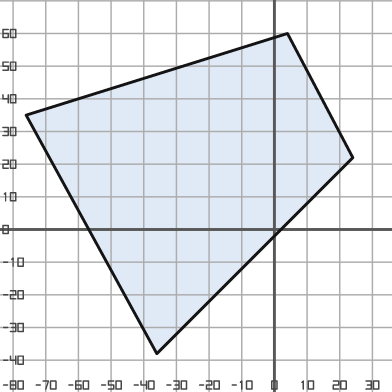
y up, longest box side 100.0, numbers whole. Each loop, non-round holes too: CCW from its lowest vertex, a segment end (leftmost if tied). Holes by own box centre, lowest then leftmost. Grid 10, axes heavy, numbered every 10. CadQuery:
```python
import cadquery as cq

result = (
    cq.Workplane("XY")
    .moveTo(-36.0, -38.0)
    .lineTo(24.0, 22.0)
    .lineTo(4.0, 60.0)
    .lineTo(-76.0, 35.0)
    .close()
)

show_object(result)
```